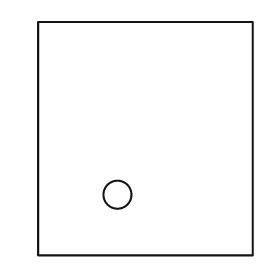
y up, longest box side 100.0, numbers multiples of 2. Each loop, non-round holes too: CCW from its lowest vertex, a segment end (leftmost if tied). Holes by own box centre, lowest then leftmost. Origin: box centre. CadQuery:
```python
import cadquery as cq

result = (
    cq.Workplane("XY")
    .moveTo(-46.0, -50.0)
    .lineTo(46.0, -50.0)
    .lineTo(46.0, 50.0)
    .lineTo(-46.0, 50.0)
    .close()
    .moveTo(-12.0, -24.0)
    .circle(6.0)
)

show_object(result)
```